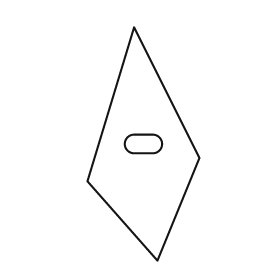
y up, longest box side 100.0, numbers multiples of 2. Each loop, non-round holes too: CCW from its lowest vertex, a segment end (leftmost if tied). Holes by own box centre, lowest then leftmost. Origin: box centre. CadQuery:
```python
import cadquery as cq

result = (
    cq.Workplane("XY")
    .moveTo(6.0, -50.0)
    .lineTo(24.0, -6.0)
    .lineTo(-4.0, 50.0)
    .lineTo(-24.0, -16.0)
    .close()
    .moveTo(-4.0, -4.0)
    .lineTo(4.0, -4.0)
    .threePointArc((8.0, 0.0), (4.0, 4.0))
    .lineTo(-4.0, 4.0)
    .threePointArc((-8.0, 0.0), (-4.0, -4.0))
    .close()
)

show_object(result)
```